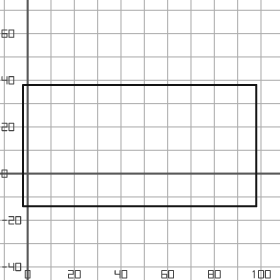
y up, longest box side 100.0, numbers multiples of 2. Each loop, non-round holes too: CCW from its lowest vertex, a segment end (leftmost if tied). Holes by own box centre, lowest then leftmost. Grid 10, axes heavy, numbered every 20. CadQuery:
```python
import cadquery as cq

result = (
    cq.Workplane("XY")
    .moveTo(-2.0, -14.0)
    .lineTo(98.0, -14.0)
    .lineTo(98.0, 38.0)
    .lineTo(-2.0, 38.0)
    .close()
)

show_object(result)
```